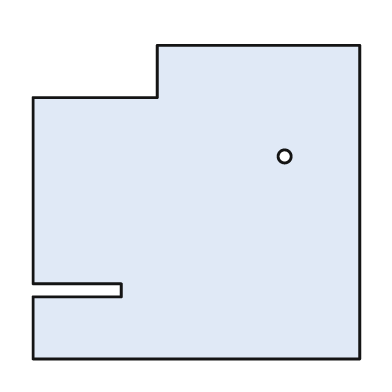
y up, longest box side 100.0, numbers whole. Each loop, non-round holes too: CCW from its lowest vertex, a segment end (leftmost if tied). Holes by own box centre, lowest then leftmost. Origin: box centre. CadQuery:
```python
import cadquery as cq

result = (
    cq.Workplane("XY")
    .moveTo(-50.0, -48.0)
    .lineTo(50.0, -48.0)
    .lineTo(50.0, 48.0)
    .lineTo(-12.0, 48.0)
    .lineTo(-12.0, 32.0)
    .lineTo(-50.0, 32.0)
    .lineTo(-50.0, -25.0)
    .lineTo(-23.0, -25.0)
    .lineTo(-23.0, -29.0)
    .lineTo(-50.0, -29.0)
    .close()
    .moveTo(27.0, 14.0)
    .circle(2.0)
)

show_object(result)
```